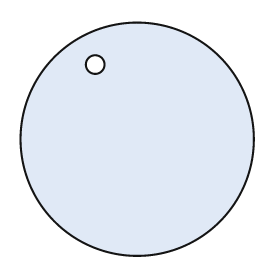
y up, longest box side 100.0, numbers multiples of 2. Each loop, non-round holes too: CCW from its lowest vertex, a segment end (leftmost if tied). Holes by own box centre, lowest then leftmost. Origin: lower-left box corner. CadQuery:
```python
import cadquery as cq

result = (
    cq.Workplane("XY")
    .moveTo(50.0, 50.0)
    .circle(50.0)
    .moveTo(32.0, 82.0)
    .circle(4.0)
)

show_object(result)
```